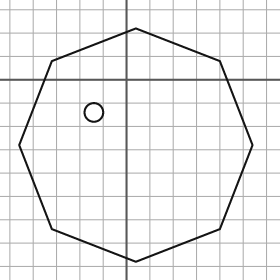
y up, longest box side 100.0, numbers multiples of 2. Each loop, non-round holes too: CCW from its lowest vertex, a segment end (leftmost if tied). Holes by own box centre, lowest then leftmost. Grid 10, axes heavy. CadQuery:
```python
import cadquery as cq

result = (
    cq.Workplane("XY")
    .moveTo(4.0, -78.0)
    .lineTo(40.0, -64.0)
    .lineTo(54.0, -28.0)
    .lineTo(40.0, 8.0)
    .lineTo(4.0, 22.0)
    .lineTo(-32.0, 8.0)
    .lineTo(-46.0, -28.0)
    .lineTo(-32.0, -64.0)
    .close()
    .moveTo(-14.0, -14.0)
    .circle(4.0)
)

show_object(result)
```